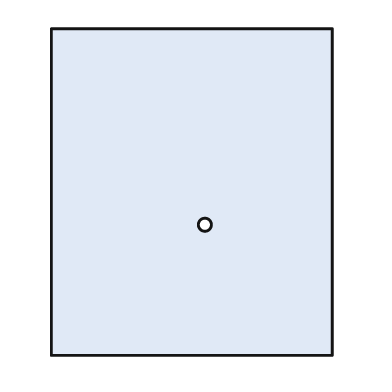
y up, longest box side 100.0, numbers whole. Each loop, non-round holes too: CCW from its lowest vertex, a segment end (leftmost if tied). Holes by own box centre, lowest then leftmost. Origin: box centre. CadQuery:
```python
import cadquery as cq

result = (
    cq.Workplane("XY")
    .moveTo(-43.0, -50.0)
    .lineTo(43.0, -50.0)
    .lineTo(43.0, 50.0)
    .lineTo(-43.0, 50.0)
    .close()
    .moveTo(4.0, -10.0)
    .circle(2.0)
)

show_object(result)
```